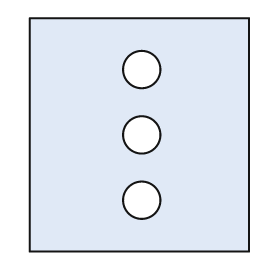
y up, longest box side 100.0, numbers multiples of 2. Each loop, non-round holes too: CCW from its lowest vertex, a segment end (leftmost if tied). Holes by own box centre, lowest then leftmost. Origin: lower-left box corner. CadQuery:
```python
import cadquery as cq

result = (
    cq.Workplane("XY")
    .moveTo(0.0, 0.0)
    .lineTo(94.0, 0.0)
    .lineTo(94.0, 100.0)
    .lineTo(0.0, 100.0)
    .close()
    .moveTo(48.0, 22.0)
    .circle(8.0)
    .moveTo(48.0, 50.0)
    .circle(8.0)
    .moveTo(48.0, 78.0)
    .circle(8.0)
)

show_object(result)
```